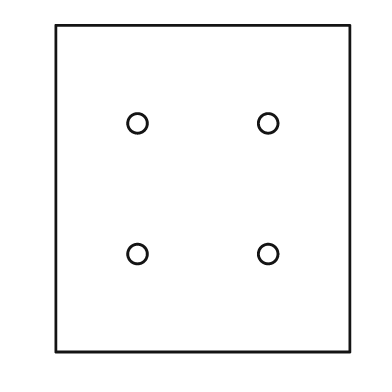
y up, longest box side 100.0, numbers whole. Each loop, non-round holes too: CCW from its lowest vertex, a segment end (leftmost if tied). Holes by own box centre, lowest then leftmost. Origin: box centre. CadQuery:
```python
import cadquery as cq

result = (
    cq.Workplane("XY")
    .moveTo(-45.0, -50.0)
    .lineTo(45.0, -50.0)
    .lineTo(45.0, 50.0)
    .lineTo(-45.0, 50.0)
    .close()
    .moveTo(-20.0, -20.0)
    .circle(3.0)
    .moveTo(20.0, -20.0)
    .circle(3.0)
    .moveTo(-20.0, 20.0)
    .circle(3.0)
    .moveTo(20.0, 20.0)
    .circle(3.0)
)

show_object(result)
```